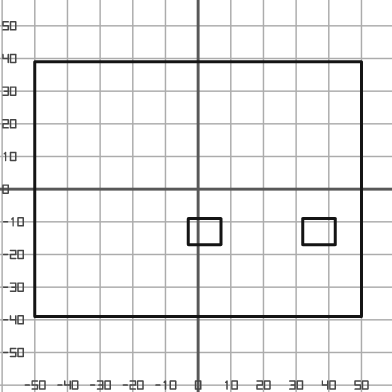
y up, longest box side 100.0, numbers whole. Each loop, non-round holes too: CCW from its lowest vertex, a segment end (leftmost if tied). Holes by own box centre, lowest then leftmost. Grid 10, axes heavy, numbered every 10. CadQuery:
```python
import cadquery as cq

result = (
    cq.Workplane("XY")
    .moveTo(-50.0, -39.0)
    .lineTo(50.0, -39.0)
    .lineTo(50.0, 39.0)
    .lineTo(-50.0, 39.0)
    .close()
    .moveTo(-3.0, -17.0)
    .lineTo(7.0, -17.0)
    .lineTo(7.0, -9.0)
    .lineTo(-3.0, -9.0)
    .close()
    .moveTo(32.0, -17.0)
    .lineTo(42.0, -17.0)
    .lineTo(42.0, -9.0)
    .lineTo(32.0, -9.0)
    .close()
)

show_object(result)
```